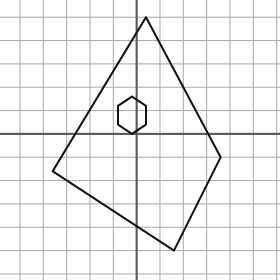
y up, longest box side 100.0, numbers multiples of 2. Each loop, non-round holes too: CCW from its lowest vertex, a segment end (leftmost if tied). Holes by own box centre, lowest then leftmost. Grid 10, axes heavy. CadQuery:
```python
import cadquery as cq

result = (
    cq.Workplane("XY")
    .moveTo(16.0, -50.0)
    .lineTo(36.0, -10.0)
    .lineTo(4.0, 50.0)
    .lineTo(-36.0, -16.0)
    .close()
    .moveTo(-2.0, 0.0)
    .lineTo(4.0, 4.0)
    .lineTo(4.0, 12.0)
    .lineTo(-2.0, 16.0)
    .lineTo(-8.0, 12.0)
    .lineTo(-8.0, 4.0)
    .close()
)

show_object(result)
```